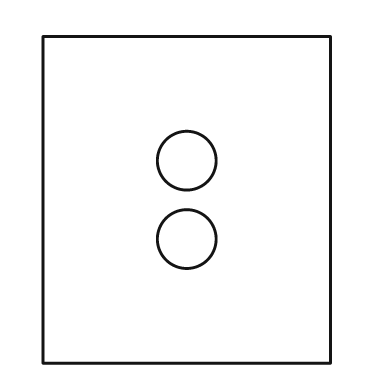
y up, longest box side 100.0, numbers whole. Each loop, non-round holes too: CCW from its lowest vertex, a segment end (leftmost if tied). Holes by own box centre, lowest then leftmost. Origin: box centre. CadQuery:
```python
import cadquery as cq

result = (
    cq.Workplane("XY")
    .moveTo(-44.0, -50.0)
    .lineTo(44.0, -50.0)
    .lineTo(44.0, 50.0)
    .lineTo(-44.0, 50.0)
    .close()
    .moveTo(0.0, -12.0)
    .circle(9.0)
    .moveTo(0.0, 12.0)
    .circle(9.0)
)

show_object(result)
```